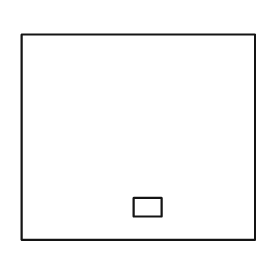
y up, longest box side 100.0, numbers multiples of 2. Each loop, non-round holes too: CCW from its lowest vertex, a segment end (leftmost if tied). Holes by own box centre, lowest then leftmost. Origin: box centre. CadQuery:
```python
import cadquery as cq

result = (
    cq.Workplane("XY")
    .moveTo(-50.0, -44.0)
    .lineTo(50.0, -44.0)
    .lineTo(50.0, 44.0)
    .lineTo(-50.0, 44.0)
    .close()
    .moveTo(-2.0, -34.0)
    .lineTo(10.0, -34.0)
    .lineTo(10.0, -26.0)
    .lineTo(-2.0, -26.0)
    .close()
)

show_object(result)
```